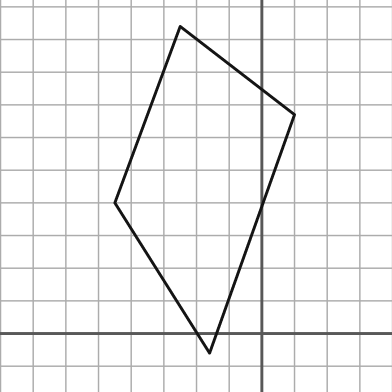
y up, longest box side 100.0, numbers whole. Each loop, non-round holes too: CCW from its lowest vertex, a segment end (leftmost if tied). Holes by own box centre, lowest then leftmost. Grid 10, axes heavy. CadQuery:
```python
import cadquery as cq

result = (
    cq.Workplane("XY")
    .moveTo(-16.0, -6.0)
    .lineTo(10.0, 67.0)
    .lineTo(-25.0, 94.0)
    .lineTo(-45.0, 40.0)
    .close()
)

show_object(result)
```